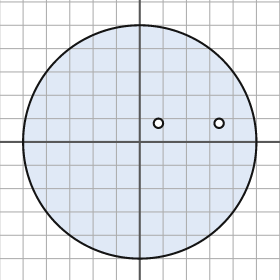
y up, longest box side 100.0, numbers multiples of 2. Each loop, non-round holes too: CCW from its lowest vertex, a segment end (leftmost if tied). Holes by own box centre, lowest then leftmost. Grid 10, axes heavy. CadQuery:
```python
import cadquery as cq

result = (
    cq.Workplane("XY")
    .moveTo(0.0, 0.0)
    .circle(50.0)
    .moveTo(8.0, 8.0)
    .circle(2.0)
    .moveTo(34.0, 8.0)
    .circle(2.0)
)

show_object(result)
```